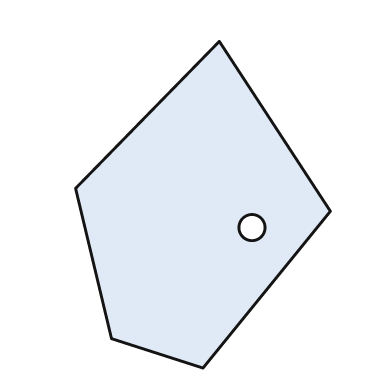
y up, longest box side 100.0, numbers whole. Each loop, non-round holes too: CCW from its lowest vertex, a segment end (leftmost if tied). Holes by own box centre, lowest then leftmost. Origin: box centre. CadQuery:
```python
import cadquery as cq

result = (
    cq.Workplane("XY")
    .moveTo(0.0, -50.0)
    .lineTo(39.0, -2.0)
    .lineTo(5.0, 50.0)
    .lineTo(-39.0, 5.0)
    .lineTo(-28.0, -41.0)
    .close()
    .moveTo(15.0, -7.0)
    .circle(4.0)
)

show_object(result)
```